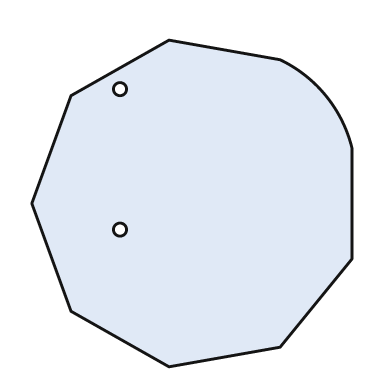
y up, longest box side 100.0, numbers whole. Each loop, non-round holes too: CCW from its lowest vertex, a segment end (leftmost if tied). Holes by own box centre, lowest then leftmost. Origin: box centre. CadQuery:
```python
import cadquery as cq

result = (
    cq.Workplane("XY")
    .moveTo(-7.0, -50.0)
    .lineTo(27.0, -44.0)
    .lineTo(49.0, -17.0)
    .lineTo(49.0, 17.0)
    .threePointArc((41.0, 33.0), (27.0, 44.0))
    .lineTo(-7.0, 50.0)
    .lineTo(-37.0, 33.0)
    .lineTo(-49.0, 0.0)
    .lineTo(-37.0, -33.0)
    .close()
    .moveTo(-22.0, -8.0)
    .circle(2.0)
    .moveTo(-22.0, 35.0)
    .circle(2.0)
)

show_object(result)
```